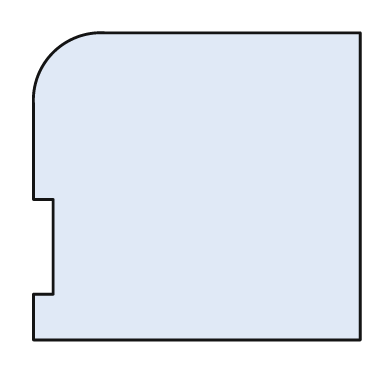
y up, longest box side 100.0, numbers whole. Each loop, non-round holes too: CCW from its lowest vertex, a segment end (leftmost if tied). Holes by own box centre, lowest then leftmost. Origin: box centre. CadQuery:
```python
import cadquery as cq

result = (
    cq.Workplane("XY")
    .moveTo(-50.0, -47.0)
    .lineTo(50.0, -47.0)
    .lineTo(50.0, 47.0)
    .lineTo(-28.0, 47.0)
    .threePointArc((-44.0, 41.0), (-50.0, 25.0))
    .lineTo(-50.0, -4.0)
    .lineTo(-44.0, -4.0)
    .lineTo(-44.0, -33.0)
    .lineTo(-50.0, -33.0)
    .close()
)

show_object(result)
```